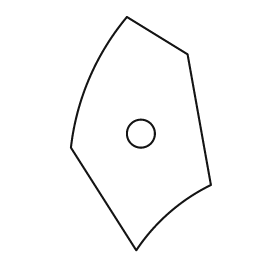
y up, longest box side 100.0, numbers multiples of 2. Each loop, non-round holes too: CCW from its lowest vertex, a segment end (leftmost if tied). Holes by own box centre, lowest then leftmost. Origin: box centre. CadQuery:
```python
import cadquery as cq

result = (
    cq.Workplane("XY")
    .moveTo(-2.0, -50.0)
    .threePointArc((12.0, -34.0), (30.0, -22.0))
    .lineTo(20.0, 34.0)
    .lineTo(-6.0, 50.0)
    .threePointArc((-22.0, 24.0), (-30.0, -6.0))
    .close()
    .moveTo(0.0, 0.0)
    .circle(6.0)
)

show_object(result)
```